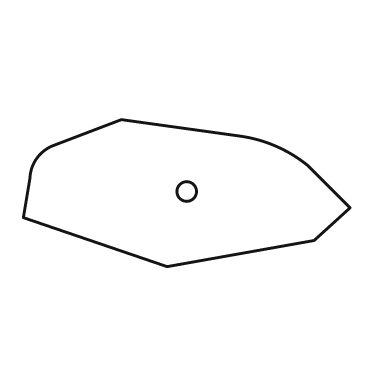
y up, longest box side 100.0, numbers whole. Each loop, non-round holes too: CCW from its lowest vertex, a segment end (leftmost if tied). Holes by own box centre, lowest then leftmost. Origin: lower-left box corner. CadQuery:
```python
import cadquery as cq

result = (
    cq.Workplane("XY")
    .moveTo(44.0, 0.0)
    .lineTo(89.0, 8.0)
    .lineTo(100.0, 18.0)
    .lineTo(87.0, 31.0)
    .threePointArc((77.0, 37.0), (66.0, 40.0))
    .lineTo(30.0, 45.0)
    .lineTo(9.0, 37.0)
    .threePointArc((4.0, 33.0), (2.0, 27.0))
    .lineTo(0.0, 15.0)
    .close()
    .moveTo(50.0, 23.0)
    .circle(3.0)
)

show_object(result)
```